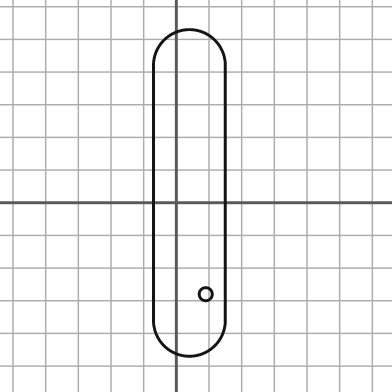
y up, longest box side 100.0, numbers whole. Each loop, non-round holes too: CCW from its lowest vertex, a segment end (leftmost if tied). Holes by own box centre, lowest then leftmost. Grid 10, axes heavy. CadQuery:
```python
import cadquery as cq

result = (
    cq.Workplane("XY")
    .moveTo(-7.0, -36.0)
    .threePointArc((4.0, -47.0), (15.0, -36.0))
    .lineTo(15.0, 42.0)
    .threePointArc((4.0, 53.0), (-7.0, 42.0))
    .close()
    .moveTo(9.0, -28.0)
    .circle(2.0)
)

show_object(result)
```